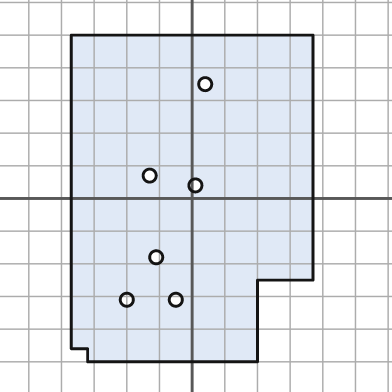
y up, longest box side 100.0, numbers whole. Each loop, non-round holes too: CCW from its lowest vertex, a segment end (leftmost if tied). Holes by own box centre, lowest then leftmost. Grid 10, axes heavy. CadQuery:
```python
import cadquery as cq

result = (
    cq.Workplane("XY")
    .moveTo(-32.0, -50.0)
    .lineTo(20.0, -50.0)
    .lineTo(20.0, -25.0)
    .lineTo(37.0, -25.0)
    .lineTo(37.0, 50.0)
    .lineTo(-37.0, 50.0)
    .lineTo(-37.0, -46.0)
    .lineTo(-32.0, -46.0)
    .close()
    .moveTo(-20.0, -31.0)
    .circle(2.0)
    .moveTo(-5.0, -31.0)
    .circle(2.0)
    .moveTo(-11.0, -18.0)
    .circle(2.0)
    .moveTo(1.0, 4.0)
    .circle(2.0)
    .moveTo(-13.0, 7.0)
    .circle(2.0)
    .moveTo(4.0, 35.0)
    .circle(2.0)
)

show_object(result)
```